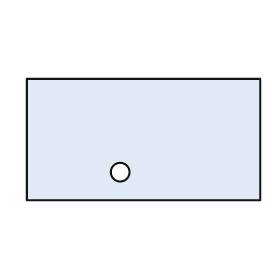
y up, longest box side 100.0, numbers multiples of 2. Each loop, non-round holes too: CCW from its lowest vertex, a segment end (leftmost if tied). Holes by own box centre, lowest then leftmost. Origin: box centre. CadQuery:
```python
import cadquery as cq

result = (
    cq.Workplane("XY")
    .moveTo(-50.0, -26.0)
    .lineTo(50.0, -26.0)
    .lineTo(50.0, 26.0)
    .lineTo(-50.0, 26.0)
    .close()
    .moveTo(-10.0, -14.0)
    .circle(4.0)
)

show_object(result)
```